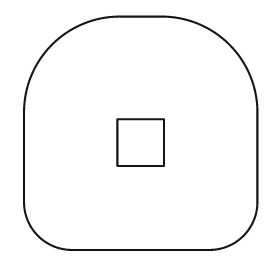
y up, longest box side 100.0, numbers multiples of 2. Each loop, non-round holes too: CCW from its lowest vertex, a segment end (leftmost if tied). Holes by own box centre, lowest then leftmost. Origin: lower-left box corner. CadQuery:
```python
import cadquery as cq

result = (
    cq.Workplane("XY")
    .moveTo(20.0, 0.0)
    .lineTo(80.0, 0.0)
    .threePointArc((94.0, 6.0), (100.0, 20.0))
    .lineTo(100.0, 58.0)
    .threePointArc((88.0, 88.0), (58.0, 100.0))
    .lineTo(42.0, 100.0)
    .threePointArc((12.0, 88.0), (0.0, 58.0))
    .lineTo(0.0, 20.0)
    .threePointArc((6.0, 6.0), (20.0, 0.0))
    .close()
    .moveTo(40.0, 36.0)
    .lineTo(60.0, 36.0)
    .lineTo(60.0, 56.0)
    .lineTo(40.0, 56.0)
    .close()
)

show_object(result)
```